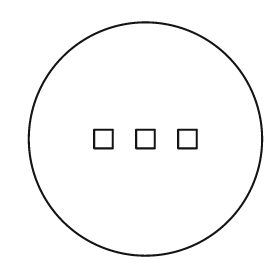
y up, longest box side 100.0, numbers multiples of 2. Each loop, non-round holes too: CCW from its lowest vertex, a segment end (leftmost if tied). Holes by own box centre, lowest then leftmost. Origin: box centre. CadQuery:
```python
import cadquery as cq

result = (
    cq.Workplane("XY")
    .moveTo(0.0, 0.0)
    .circle(50.0)
    .moveTo(-22.0, -4.0)
    .lineTo(-14.0, -4.0)
    .lineTo(-14.0, 4.0)
    .lineTo(-22.0, 4.0)
    .close()
    .moveTo(-4.0, -4.0)
    .lineTo(4.0, -4.0)
    .lineTo(4.0, 4.0)
    .lineTo(-4.0, 4.0)
    .close()
    .moveTo(14.0, -4.0)
    .lineTo(22.0, -4.0)
    .lineTo(22.0, 4.0)
    .lineTo(14.0, 4.0)
    .close()
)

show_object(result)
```